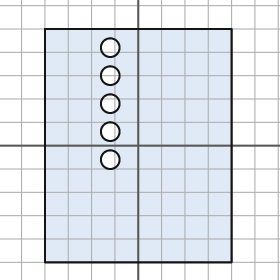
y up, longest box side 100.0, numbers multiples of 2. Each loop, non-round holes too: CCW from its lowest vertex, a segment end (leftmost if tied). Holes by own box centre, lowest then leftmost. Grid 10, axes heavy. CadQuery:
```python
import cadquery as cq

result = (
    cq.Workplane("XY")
    .moveTo(-40.0, -50.0)
    .lineTo(40.0, -50.0)
    .lineTo(40.0, 50.0)
    .lineTo(-40.0, 50.0)
    .close()
    .moveTo(-12.0, -6.0)
    .circle(4.0)
    .moveTo(-12.0, 6.0)
    .circle(4.0)
    .moveTo(-12.0, 18.0)
    .circle(4.0)
    .moveTo(-12.0, 30.0)
    .circle(4.0)
    .moveTo(-12.0, 42.0)
    .circle(4.0)
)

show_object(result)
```